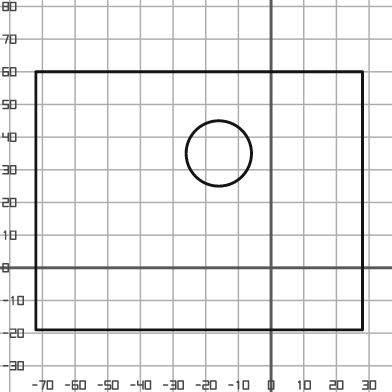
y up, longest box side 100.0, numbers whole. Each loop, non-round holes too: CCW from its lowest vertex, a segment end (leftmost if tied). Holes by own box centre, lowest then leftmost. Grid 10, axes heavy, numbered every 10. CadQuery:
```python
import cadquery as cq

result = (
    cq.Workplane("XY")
    .moveTo(-72.0, -19.0)
    .lineTo(28.0, -19.0)
    .lineTo(28.0, 60.0)
    .lineTo(-72.0, 60.0)
    .close()
    .moveTo(-16.0, 35.0)
    .circle(10.0)
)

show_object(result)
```